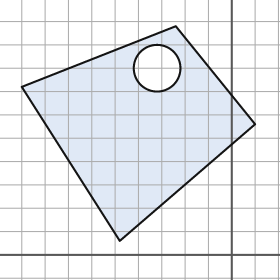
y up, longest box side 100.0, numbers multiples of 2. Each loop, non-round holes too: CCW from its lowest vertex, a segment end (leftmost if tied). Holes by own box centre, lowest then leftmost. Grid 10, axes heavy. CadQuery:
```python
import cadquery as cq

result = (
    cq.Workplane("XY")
    .moveTo(-48.0, 6.0)
    .lineTo(10.0, 56.0)
    .lineTo(-24.0, 98.0)
    .lineTo(-90.0, 72.0)
    .close()
    .moveTo(-32.0, 80.0)
    .circle(10.0)
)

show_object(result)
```